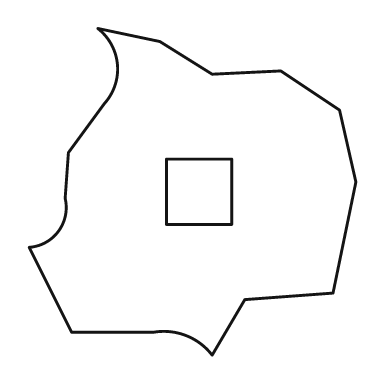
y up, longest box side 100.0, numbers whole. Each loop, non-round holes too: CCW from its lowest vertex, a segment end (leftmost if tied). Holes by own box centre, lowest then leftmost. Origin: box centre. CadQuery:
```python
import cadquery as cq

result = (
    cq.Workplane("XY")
    .moveTo(6.0, -50.0)
    .lineTo(16.0, -33.0)
    .lineTo(43.0, -31.0)
    .lineTo(50.0, 3.0)
    .lineTo(45.0, 25.0)
    .lineTo(27.0, 37.0)
    .lineTo(6.0, 36.0)
    .lineTo(-10.0, 46.0)
    .lineTo(-29.0, 50.0)
    .threePointArc((-23.0, 39.0), (-27.0, 27.0))
    .lineTo(-38.0, 12.0)
    .lineTo(-39.0, -2.0)
    .threePointArc((-41.0, -12.0), (-50.0, -17.0))
    .lineTo(-37.0, -43.0)
    .lineTo(-12.0, -43.0)
    .threePointArc((-2.0, -44.0), (6.0, -50.0))
    .close()
    .moveTo(-8.0, -10.0)
    .lineTo(12.0, -10.0)
    .lineTo(12.0, 10.0)
    .lineTo(-8.0, 10.0)
    .close()
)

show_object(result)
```